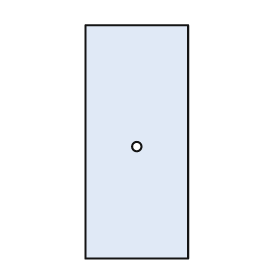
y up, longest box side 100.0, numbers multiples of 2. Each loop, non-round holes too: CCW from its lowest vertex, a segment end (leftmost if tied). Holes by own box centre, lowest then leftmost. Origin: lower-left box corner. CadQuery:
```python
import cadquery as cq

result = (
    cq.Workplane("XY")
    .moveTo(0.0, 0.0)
    .lineTo(44.0, 0.0)
    .lineTo(44.0, 100.0)
    .lineTo(0.0, 100.0)
    .close()
    .moveTo(22.0, 48.0)
    .circle(2.0)
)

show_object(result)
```